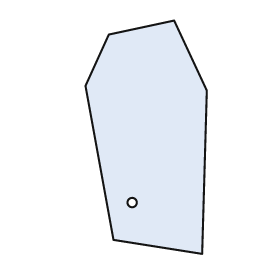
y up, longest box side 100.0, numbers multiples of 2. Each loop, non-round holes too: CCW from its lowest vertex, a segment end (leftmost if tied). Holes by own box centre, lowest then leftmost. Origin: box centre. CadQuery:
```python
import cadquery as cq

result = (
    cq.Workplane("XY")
    .moveTo(24.0, -50.0)
    .lineTo(26.0, 20.0)
    .lineTo(12.0, 50.0)
    .lineTo(-16.0, 44.0)
    .lineTo(-26.0, 22.0)
    .lineTo(-14.0, -44.0)
    .close()
    .moveTo(-6.0, -28.0)
    .circle(2.0)
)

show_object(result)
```